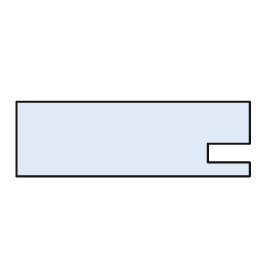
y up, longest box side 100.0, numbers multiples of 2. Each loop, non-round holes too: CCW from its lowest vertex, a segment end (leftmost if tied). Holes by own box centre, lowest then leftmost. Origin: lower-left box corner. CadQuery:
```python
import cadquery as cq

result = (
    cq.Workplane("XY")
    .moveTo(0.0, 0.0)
    .lineTo(100.0, 0.0)
    .lineTo(100.0, 6.0)
    .lineTo(82.0, 6.0)
    .lineTo(82.0, 14.0)
    .lineTo(100.0, 14.0)
    .lineTo(100.0, 32.0)
    .lineTo(0.0, 32.0)
    .close()
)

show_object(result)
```